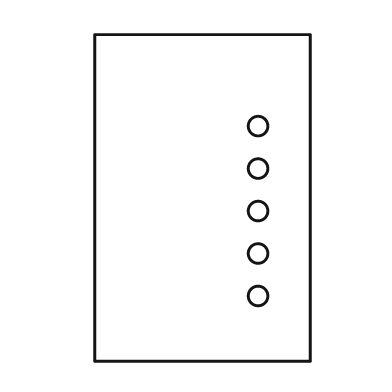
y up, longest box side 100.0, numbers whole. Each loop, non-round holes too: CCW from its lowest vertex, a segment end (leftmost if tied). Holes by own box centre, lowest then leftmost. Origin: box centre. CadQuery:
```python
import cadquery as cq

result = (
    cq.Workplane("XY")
    .moveTo(-33.0, -50.0)
    .lineTo(33.0, -50.0)
    .lineTo(33.0, 50.0)
    .lineTo(-33.0, 50.0)
    .close()
    .moveTo(17.0, -30.0)
    .circle(3.0)
    .moveTo(17.0, -17.0)
    .circle(3.0)
    .moveTo(17.0, -4.0)
    .circle(3.0)
    .moveTo(17.0, 9.0)
    .circle(3.0)
    .moveTo(17.0, 22.0)
    .circle(3.0)
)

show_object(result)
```